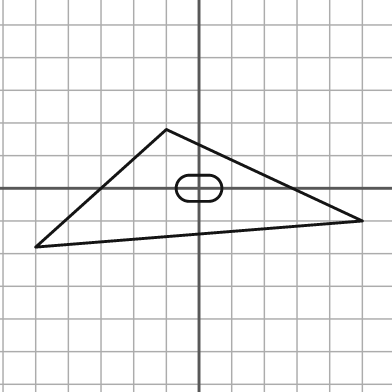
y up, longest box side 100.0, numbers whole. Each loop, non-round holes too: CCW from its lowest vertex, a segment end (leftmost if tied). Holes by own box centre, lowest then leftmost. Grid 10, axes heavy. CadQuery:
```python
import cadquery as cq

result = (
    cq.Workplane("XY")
    .moveTo(-50.0, -18.0)
    .lineTo(50.0, -10.0)
    .lineTo(-10.0, 18.0)
    .close()
    .moveTo(-3.0, -4.0)
    .lineTo(3.0, -4.0)
    .threePointArc((7.0, 0.0), (3.0, 4.0))
    .lineTo(-3.0, 4.0)
    .threePointArc((-7.0, 0.0), (-3.0, -4.0))
    .close()
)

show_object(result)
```